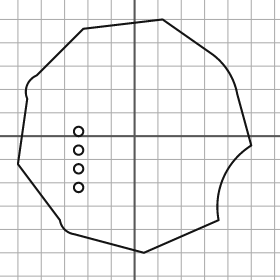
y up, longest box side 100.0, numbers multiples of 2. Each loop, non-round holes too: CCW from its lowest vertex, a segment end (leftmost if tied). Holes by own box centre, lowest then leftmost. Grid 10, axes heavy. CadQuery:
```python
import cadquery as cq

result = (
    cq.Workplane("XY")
    .moveTo(4.0, -50.0)
    .lineTo(36.0, -36.0)
    .threePointArc((38.0, -18.0), (50.0, -4.0))
    .lineTo(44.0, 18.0)
    .threePointArc((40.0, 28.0), (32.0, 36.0))
    .lineTo(12.0, 50.0)
    .lineTo(-22.0, 46.0)
    .lineTo(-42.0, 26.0)
    .threePointArc((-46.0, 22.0), (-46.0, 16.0))
    .lineTo(-50.0, -12.0)
    .lineTo(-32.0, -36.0)
    .threePointArc((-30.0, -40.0), (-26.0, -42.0))
    .close()
    .moveTo(-24.0, -22.0)
    .circle(2.0)
    .moveTo(-24.0, -14.0)
    .circle(2.0)
    .moveTo(-24.0, -6.0)
    .circle(2.0)
    .moveTo(-24.0, 2.0)
    .circle(2.0)
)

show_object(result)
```